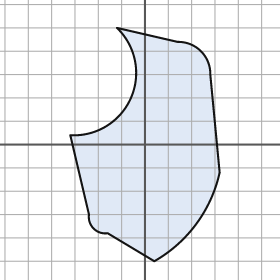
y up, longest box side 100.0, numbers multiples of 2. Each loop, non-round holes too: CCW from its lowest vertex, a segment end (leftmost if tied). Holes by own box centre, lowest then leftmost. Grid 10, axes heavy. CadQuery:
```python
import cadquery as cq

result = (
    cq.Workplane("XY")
    .moveTo(4.0, -50.0)
    .threePointArc((22.0, -34.0), (32.0, -12.0))
    .lineTo(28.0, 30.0)
    .threePointArc((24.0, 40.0), (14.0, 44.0))
    .lineTo(-12.0, 50.0)
    .threePointArc((-6.0, 20.0), (-32.0, 4.0))
    .lineTo(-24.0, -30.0)
    .threePointArc((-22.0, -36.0), (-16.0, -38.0))
    .close()
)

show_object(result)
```